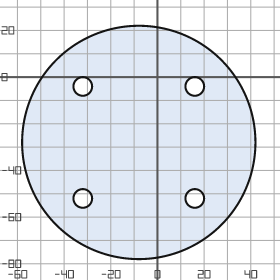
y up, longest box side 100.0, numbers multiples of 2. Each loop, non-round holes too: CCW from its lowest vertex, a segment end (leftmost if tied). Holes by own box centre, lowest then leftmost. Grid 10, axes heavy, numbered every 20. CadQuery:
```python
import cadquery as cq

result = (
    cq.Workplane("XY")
    .moveTo(-8.0, -28.0)
    .circle(50.0)
    .moveTo(-32.0, -52.0)
    .circle(4.0)
    .moveTo(16.0, -52.0)
    .circle(4.0)
    .moveTo(-32.0, -4.0)
    .circle(4.0)
    .moveTo(16.0, -4.0)
    .circle(4.0)
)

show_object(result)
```